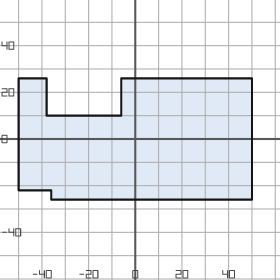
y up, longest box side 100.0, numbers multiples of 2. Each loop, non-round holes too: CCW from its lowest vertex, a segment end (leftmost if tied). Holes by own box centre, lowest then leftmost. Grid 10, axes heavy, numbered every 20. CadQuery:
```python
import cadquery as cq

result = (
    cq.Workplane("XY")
    .moveTo(-36.0, -26.0)
    .lineTo(50.0, -26.0)
    .lineTo(50.0, 26.0)
    .lineTo(-6.0, 26.0)
    .lineTo(-6.0, 10.0)
    .lineTo(-38.0, 10.0)
    .lineTo(-38.0, 26.0)
    .lineTo(-50.0, 26.0)
    .lineTo(-50.0, -22.0)
    .lineTo(-36.0, -22.0)
    .close()
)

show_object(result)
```